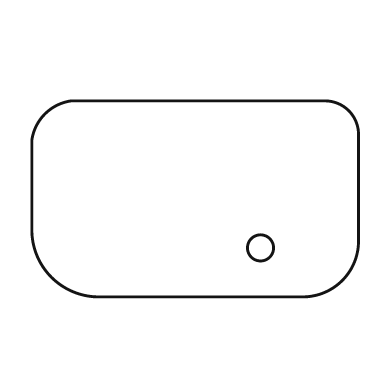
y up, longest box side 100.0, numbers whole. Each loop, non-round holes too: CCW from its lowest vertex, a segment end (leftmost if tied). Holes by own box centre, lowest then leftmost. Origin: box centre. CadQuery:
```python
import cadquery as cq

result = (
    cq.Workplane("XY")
    .moveTo(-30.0, -30.0)
    .lineTo(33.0, -30.0)
    .threePointArc((45.0, -25.0), (50.0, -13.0))
    .lineTo(50.0, 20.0)
    .threePointArc((47.0, 27.0), (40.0, 30.0))
    .lineTo(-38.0, 30.0)
    .threePointArc((-46.0, 26.0), (-50.0, 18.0))
    .lineTo(-50.0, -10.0)
    .threePointArc((-44.0, -24.0), (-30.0, -30.0))
    .close()
    .moveTo(20.0, -15.0)
    .circle(4.0)
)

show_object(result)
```